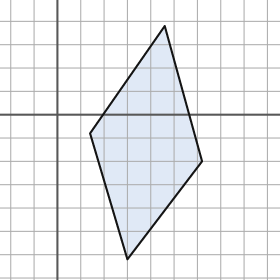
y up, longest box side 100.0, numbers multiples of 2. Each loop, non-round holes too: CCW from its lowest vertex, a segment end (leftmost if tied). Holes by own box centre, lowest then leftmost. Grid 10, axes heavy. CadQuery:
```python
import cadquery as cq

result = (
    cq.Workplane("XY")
    .moveTo(30.0, -62.0)
    .lineTo(62.0, -20.0)
    .lineTo(46.0, 38.0)
    .lineTo(14.0, -8.0)
    .close()
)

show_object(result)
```